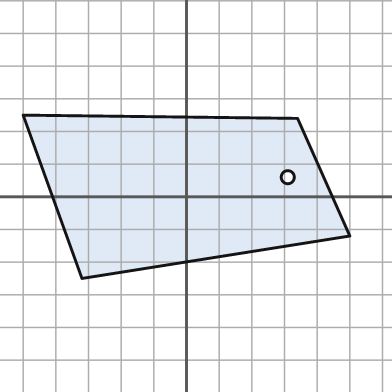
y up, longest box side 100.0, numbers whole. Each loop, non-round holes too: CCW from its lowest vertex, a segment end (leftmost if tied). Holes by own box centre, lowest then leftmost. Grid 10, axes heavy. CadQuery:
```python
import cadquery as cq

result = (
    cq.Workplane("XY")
    .moveTo(-32.0, -25.0)
    .lineTo(50.0, -12.0)
    .lineTo(34.0, 24.0)
    .lineTo(-50.0, 25.0)
    .close()
    .moveTo(31.0, 6.0)
    .circle(2.0)
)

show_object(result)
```